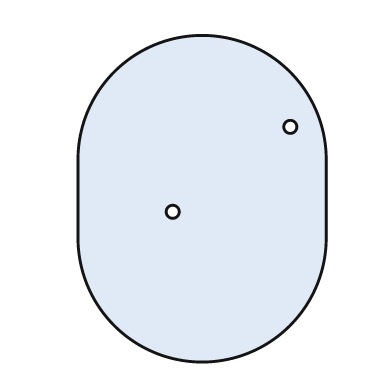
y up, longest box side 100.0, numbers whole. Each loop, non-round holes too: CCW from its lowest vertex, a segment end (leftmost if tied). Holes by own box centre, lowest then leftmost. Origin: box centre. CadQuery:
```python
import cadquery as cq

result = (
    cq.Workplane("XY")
    .moveTo(-38.0, -12.0)
    .threePointArc((0.0, -50.0), (38.0, -12.0))
    .lineTo(38.0, 12.0)
    .threePointArc((0.0, 50.0), (-38.0, 12.0))
    .close()
    .moveTo(-9.0, -4.0)
    .circle(2.0)
    .moveTo(27.0, 22.0)
    .circle(2.0)
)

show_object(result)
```